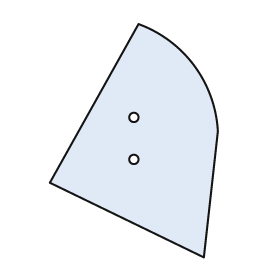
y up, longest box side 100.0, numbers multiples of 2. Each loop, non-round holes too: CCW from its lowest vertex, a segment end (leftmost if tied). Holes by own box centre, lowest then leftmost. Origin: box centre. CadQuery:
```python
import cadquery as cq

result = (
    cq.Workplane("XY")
    .moveTo(30.0, -50.0)
    .lineTo(36.0, 4.0)
    .threePointArc((26.0, 32.0), (2.0, 50.0))
    .lineTo(-36.0, -18.0)
    .close()
    .moveTo(0.0, -8.0)
    .circle(2.0)
    .moveTo(0.0, 10.0)
    .circle(2.0)
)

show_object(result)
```